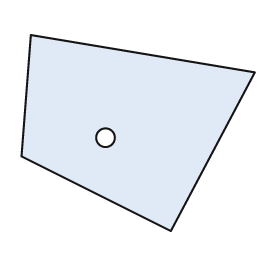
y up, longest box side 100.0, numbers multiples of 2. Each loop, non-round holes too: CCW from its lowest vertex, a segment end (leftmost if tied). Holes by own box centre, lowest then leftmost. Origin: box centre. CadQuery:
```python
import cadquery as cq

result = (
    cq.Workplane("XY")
    .moveTo(14.0, -42.0)
    .lineTo(50.0, 26.0)
    .lineTo(-46.0, 42.0)
    .lineTo(-50.0, -10.0)
    .close()
    .moveTo(-14.0, -2.0)
    .circle(4.0)
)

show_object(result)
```